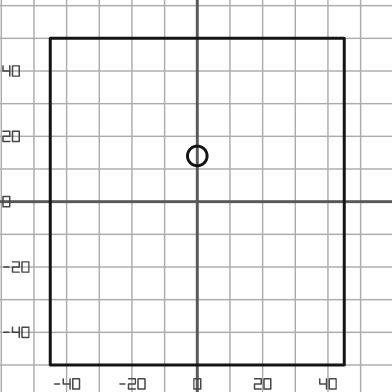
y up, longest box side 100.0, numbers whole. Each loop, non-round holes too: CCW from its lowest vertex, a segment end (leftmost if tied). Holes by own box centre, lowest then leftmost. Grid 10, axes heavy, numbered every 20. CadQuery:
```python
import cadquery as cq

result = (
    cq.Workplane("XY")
    .moveTo(-45.0, -50.0)
    .lineTo(45.0, -50.0)
    .lineTo(45.0, 50.0)
    .lineTo(-45.0, 50.0)
    .close()
    .moveTo(0.0, 14.0)
    .circle(3.0)
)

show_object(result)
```